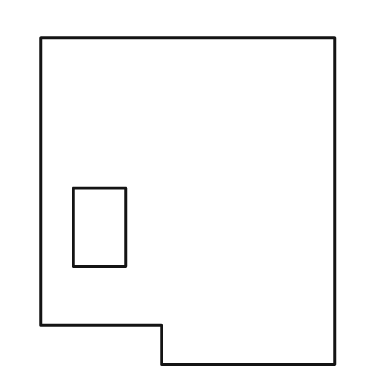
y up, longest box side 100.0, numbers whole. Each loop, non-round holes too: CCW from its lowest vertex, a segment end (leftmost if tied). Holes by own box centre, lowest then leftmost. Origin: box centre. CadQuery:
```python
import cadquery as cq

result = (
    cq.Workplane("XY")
    .moveTo(-8.0, -50.0)
    .lineTo(45.0, -50.0)
    .lineTo(45.0, 50.0)
    .lineTo(-45.0, 50.0)
    .lineTo(-45.0, -38.0)
    .lineTo(-8.0, -38.0)
    .close()
    .moveTo(-35.0, -20.0)
    .lineTo(-19.0, -20.0)
    .lineTo(-19.0, 4.0)
    .lineTo(-35.0, 4.0)
    .close()
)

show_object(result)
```